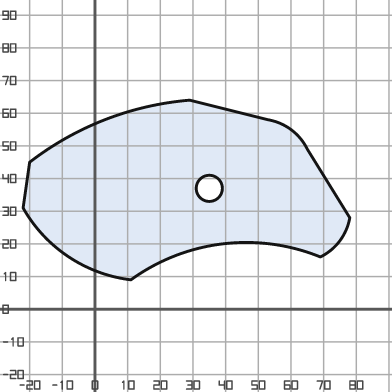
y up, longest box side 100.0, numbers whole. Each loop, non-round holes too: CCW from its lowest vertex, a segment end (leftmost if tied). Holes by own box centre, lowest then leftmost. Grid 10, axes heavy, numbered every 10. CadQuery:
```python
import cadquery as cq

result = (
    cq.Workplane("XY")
    .moveTo(11.0, 9.0)
    .threePointArc((39.0, 20.0), (69.0, 16.0))
    .threePointArc((75.0, 21.0), (78.0, 28.0))
    .lineTo(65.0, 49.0)
    .threePointArc((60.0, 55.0), (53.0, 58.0))
    .lineTo(29.0, 64.0)
    .threePointArc((3.0, 58.0), (-20.0, 45.0))
    .lineTo(-22.0, 31.0)
    .threePointArc((-8.0, 16.0), (11.0, 9.0))
    .close()
    .moveTo(35.0, 37.0)
    .circle(4.0)
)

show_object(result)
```